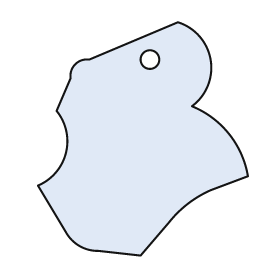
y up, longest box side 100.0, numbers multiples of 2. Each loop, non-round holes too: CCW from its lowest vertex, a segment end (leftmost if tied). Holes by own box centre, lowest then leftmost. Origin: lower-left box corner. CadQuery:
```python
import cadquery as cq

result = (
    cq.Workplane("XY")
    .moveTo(44.0, 0.0)
    .lineTo(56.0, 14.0)
    .threePointArc((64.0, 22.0), (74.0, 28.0))
    .lineTo(90.0, 34.0)
    .threePointArc((82.0, 52.0), (66.0, 64.0))
    .threePointArc((74.0, 84.0), (60.0, 100.0))
    .lineTo(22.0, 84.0)
    .threePointArc((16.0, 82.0), (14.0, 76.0))
    .lineTo(8.0, 62.0)
    .threePointArc((12.0, 44.0), (0.0, 30.0))
    .lineTo(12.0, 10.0)
    .threePointArc((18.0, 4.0), (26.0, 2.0))
    .close()
    .moveTo(48.0, 84.0)
    .circle(4.0)
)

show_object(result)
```